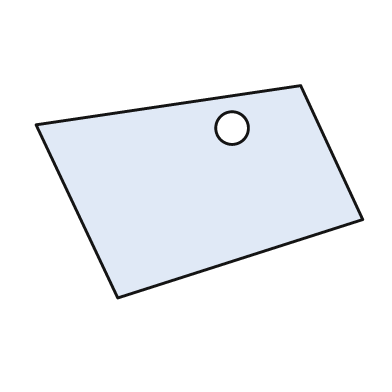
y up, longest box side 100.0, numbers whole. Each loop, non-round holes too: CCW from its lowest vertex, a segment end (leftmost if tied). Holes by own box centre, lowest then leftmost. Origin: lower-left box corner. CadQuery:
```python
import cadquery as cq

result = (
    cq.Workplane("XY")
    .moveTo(25.0, 0.0)
    .lineTo(100.0, 24.0)
    .lineTo(81.0, 65.0)
    .lineTo(0.0, 53.0)
    .close()
    .moveTo(60.0, 52.0)
    .circle(5.0)
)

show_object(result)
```